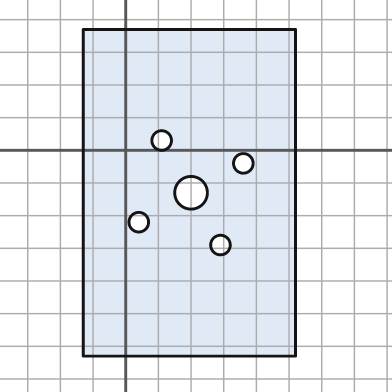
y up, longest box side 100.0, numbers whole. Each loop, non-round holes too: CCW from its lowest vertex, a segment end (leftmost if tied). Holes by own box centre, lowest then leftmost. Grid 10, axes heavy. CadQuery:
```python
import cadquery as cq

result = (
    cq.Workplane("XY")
    .moveTo(-13.0, -63.0)
    .lineTo(52.0, -63.0)
    .lineTo(52.0, 37.0)
    .lineTo(-13.0, 37.0)
    .close()
    .moveTo(29.0, -29.0)
    .circle(3.0)
    .moveTo(4.0, -22.0)
    .circle(3.0)
    .moveTo(20.0, -13.0)
    .circle(5.0)
    .moveTo(36.0, -4.0)
    .circle(3.0)
    .moveTo(11.0, 3.0)
    .circle(3.0)
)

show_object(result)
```